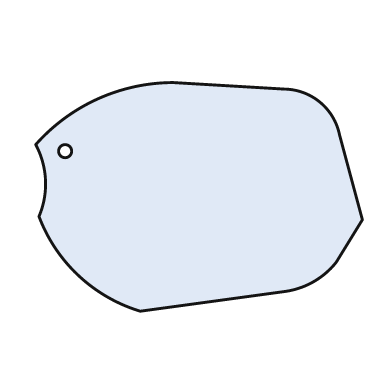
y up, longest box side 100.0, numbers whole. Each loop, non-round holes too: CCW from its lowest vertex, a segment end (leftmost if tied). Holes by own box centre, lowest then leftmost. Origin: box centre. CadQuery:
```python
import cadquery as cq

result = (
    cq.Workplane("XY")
    .moveTo(-18.0, -35.0)
    .lineTo(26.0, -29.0)
    .threePointArc((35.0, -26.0), (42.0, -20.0))
    .lineTo(50.0, -7.0)
    .lineTo(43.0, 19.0)
    .threePointArc((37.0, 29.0), (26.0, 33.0))
    .lineTo(-8.0, 35.0)
    .threePointArc((-31.0, 30.0), (-50.0, 16.0))
    .threePointArc((-47.0, 5.0), (-49.0, -6.0))
    .threePointArc((-37.0, -24.0), (-18.0, -35.0))
    .close()
    .moveTo(-41.0, 14.0)
    .circle(2.0)
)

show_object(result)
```